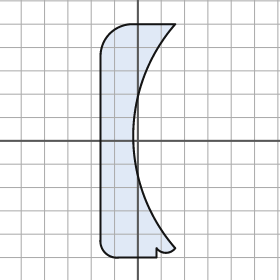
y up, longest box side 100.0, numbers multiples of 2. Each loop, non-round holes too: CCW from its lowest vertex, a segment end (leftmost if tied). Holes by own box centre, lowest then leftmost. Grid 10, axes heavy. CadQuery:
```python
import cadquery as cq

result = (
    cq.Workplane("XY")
    .moveTo(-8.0, -50.0)
    .lineTo(8.0, -50.0)
    .lineTo(8.0, -46.0)
    .threePointArc((12.0, -48.0), (16.0, -46.0))
    .threePointArc((-2.0, 2.0), (16.0, 50.0))
    .lineTo(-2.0, 50.0)
    .threePointArc((-12.0, 46.0), (-16.0, 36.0))
    .lineTo(-16.0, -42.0)
    .threePointArc((-14.0, -48.0), (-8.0, -50.0))
    .close()
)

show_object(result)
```